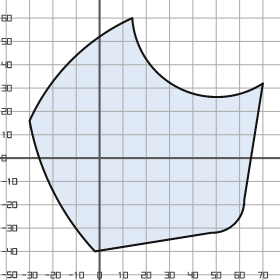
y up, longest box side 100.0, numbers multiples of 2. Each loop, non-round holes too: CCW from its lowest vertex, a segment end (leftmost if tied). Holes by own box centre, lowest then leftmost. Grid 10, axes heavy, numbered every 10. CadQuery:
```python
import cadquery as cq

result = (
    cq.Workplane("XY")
    .moveTo(-2.0, -40.0)
    .lineTo(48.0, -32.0)
    .threePointArc((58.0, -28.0), (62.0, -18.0))
    .lineTo(70.0, 32.0)
    .threePointArc((34.0, 30.0), (14.0, 60.0))
    .threePointArc((-12.0, 42.0), (-30.0, 16.0))
    .threePointArc((-20.0, -14.0), (-2.0, -40.0))
    .close()
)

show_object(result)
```